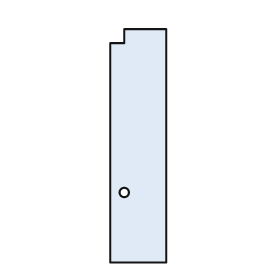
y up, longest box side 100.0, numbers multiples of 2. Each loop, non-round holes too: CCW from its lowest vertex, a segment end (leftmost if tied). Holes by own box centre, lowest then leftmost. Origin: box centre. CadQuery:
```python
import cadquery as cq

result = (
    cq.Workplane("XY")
    .moveTo(-12.0, -50.0)
    .lineTo(12.0, -50.0)
    .lineTo(12.0, 50.0)
    .lineTo(-6.0, 50.0)
    .lineTo(-6.0, 44.0)
    .lineTo(-12.0, 44.0)
    .close()
    .moveTo(-6.0, -20.0)
    .circle(2.0)
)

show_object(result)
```